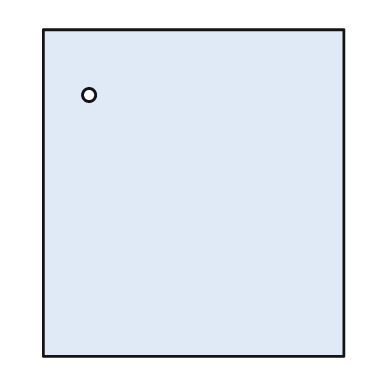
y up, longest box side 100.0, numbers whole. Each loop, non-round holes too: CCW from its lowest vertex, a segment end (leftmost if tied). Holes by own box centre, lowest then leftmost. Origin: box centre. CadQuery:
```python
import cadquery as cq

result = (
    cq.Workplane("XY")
    .moveTo(-46.0, -50.0)
    .lineTo(46.0, -50.0)
    .lineTo(46.0, 50.0)
    .lineTo(-46.0, 50.0)
    .close()
    .moveTo(-32.0, 30.0)
    .circle(2.0)
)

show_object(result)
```